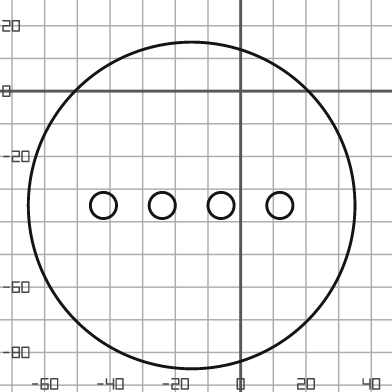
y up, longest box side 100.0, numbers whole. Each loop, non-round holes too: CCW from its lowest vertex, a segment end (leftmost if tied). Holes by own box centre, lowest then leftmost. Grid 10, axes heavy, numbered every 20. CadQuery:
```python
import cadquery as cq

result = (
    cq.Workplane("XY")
    .moveTo(-15.0, -35.0)
    .circle(50.0)
    .moveTo(-42.0, -35.0)
    .circle(4.0)
    .moveTo(-24.0, -35.0)
    .circle(4.0)
    .moveTo(-6.0, -35.0)
    .circle(4.0)
    .moveTo(12.0, -35.0)
    .circle(4.0)
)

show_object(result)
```